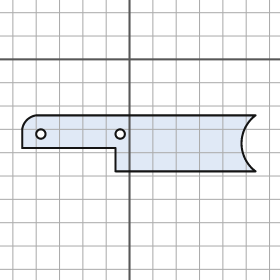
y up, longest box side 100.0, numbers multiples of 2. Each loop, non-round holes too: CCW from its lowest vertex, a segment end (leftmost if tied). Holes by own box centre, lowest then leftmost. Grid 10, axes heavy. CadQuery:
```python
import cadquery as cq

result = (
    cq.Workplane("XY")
    .moveTo(-6.0, -48.0)
    .lineTo(54.0, -48.0)
    .threePointArc((48.0, -36.0), (54.0, -24.0))
    .lineTo(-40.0, -24.0)
    .threePointArc((-44.0, -26.0), (-46.0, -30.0))
    .lineTo(-46.0, -38.0)
    .lineTo(-6.0, -38.0)
    .close()
    .moveTo(-38.0, -32.0)
    .circle(2.0)
    .moveTo(-4.0, -32.0)
    .circle(2.0)
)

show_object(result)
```